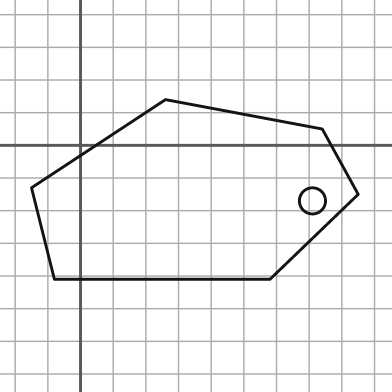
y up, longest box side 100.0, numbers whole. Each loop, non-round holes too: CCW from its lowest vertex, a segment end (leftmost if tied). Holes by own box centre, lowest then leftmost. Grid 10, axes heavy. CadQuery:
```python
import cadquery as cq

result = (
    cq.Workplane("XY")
    .moveTo(-8.0, -41.0)
    .lineTo(58.0, -41.0)
    .lineTo(85.0, -15.0)
    .lineTo(74.0, 5.0)
    .lineTo(26.0, 14.0)
    .lineTo(-15.0, -13.0)
    .close()
    .moveTo(71.0, -17.0)
    .circle(4.0)
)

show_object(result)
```